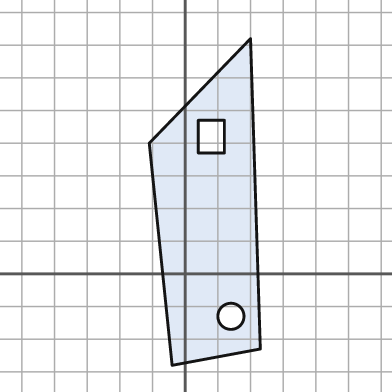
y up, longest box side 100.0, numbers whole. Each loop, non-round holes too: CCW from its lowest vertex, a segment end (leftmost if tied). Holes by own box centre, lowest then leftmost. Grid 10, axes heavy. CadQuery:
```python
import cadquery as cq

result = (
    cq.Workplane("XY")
    .moveTo(-4.0, -28.0)
    .lineTo(23.0, -23.0)
    .lineTo(20.0, 72.0)
    .lineTo(-11.0, 40.0)
    .close()
    .moveTo(14.0, -13.0)
    .circle(4.0)
    .moveTo(4.0, 37.0)
    .lineTo(12.0, 37.0)
    .lineTo(12.0, 47.0)
    .lineTo(4.0, 47.0)
    .close()
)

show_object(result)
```